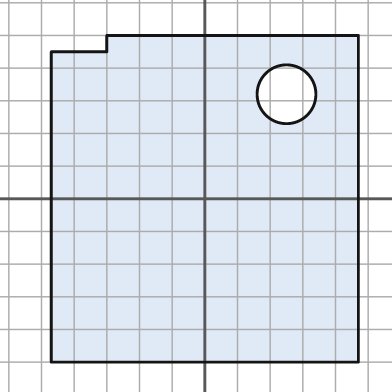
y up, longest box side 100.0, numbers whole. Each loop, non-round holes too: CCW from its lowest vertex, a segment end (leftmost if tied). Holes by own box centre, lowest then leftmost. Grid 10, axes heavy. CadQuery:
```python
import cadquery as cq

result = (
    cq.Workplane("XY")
    .moveTo(-47.0, -50.0)
    .lineTo(47.0, -50.0)
    .lineTo(47.0, 50.0)
    .lineTo(-30.0, 50.0)
    .lineTo(-30.0, 45.0)
    .lineTo(-47.0, 45.0)
    .close()
    .moveTo(25.0, 32.0)
    .circle(9.0)
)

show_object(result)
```